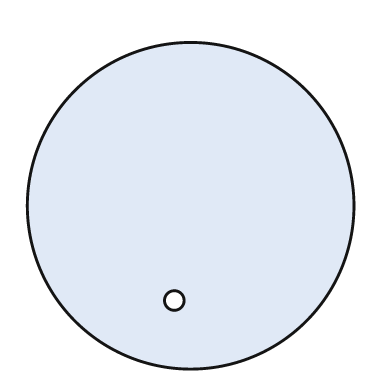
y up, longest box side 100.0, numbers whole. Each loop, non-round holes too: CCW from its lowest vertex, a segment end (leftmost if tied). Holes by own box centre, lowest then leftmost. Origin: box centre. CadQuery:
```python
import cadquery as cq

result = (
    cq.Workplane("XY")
    .moveTo(0.0, 0.0)
    .circle(50.0)
    .moveTo(-5.0, -29.0)
    .circle(3.0)
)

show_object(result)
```